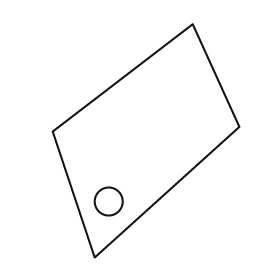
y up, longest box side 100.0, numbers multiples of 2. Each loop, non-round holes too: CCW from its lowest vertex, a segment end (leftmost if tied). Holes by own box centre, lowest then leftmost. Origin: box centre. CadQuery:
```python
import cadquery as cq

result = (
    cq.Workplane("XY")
    .moveTo(-22.0, -50.0)
    .lineTo(40.0, 6.0)
    .lineTo(20.0, 50.0)
    .lineTo(-40.0, 4.0)
    .close()
    .moveTo(-16.0, -26.0)
    .circle(6.0)
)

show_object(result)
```